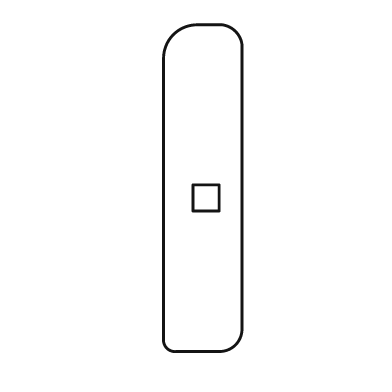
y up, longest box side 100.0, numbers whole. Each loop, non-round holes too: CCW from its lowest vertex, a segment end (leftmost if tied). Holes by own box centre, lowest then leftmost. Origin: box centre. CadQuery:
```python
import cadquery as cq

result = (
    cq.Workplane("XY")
    .moveTo(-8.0, -50.0)
    .lineTo(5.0, -50.0)
    .threePointArc((10.0, -48.0), (12.0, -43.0))
    .lineTo(12.0, 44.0)
    .threePointArc((10.0, 48.0), (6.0, 50.0))
    .lineTo(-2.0, 50.0)
    .threePointArc((-9.0, 47.0), (-12.0, 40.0))
    .lineTo(-12.0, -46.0)
    .threePointArc((-11.0, -49.0), (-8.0, -50.0))
    .close()
    .moveTo(-3.0, -7.0)
    .lineTo(5.0, -7.0)
    .lineTo(5.0, 1.0)
    .lineTo(-3.0, 1.0)
    .close()
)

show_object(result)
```